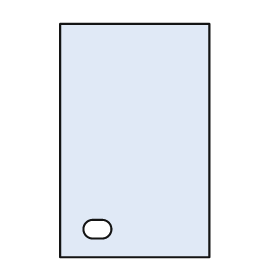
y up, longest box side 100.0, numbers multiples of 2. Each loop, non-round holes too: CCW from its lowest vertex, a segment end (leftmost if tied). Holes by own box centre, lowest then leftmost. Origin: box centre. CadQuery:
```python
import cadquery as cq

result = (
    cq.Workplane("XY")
    .moveTo(-32.0, -50.0)
    .lineTo(32.0, -50.0)
    .lineTo(32.0, 50.0)
    .lineTo(-32.0, 50.0)
    .close()
    .moveTo(-18.0, -42.0)
    .lineTo(-14.0, -42.0)
    .threePointArc((-10.0, -38.0), (-14.0, -34.0))
    .lineTo(-18.0, -34.0)
    .threePointArc((-22.0, -38.0), (-18.0, -42.0))
    .close()
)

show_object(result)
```